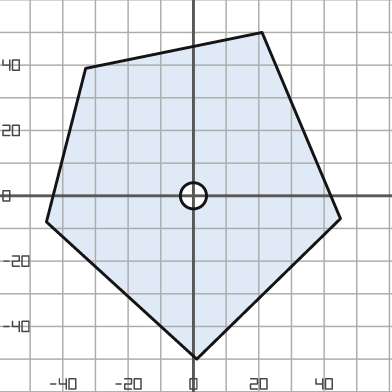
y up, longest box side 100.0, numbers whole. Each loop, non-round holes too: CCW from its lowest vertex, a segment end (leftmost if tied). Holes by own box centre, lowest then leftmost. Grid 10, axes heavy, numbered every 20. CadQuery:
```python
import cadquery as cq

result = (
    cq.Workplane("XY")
    .moveTo(1.0, -50.0)
    .lineTo(45.0, -7.0)
    .lineTo(21.0, 50.0)
    .lineTo(-33.0, 39.0)
    .lineTo(-45.0, -8.0)
    .close()
    .moveTo(0.0, 0.0)
    .circle(4.0)
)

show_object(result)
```